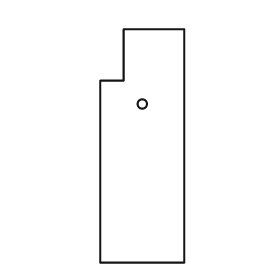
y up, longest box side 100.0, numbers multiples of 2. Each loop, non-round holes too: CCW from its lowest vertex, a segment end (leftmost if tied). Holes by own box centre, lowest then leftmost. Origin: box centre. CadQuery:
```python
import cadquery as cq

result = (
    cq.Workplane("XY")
    .moveTo(-18.0, -50.0)
    .lineTo(18.0, -50.0)
    .lineTo(18.0, 50.0)
    .lineTo(-8.0, 50.0)
    .lineTo(-8.0, 28.0)
    .lineTo(-18.0, 28.0)
    .close()
    .moveTo(0.0, 18.0)
    .circle(2.0)
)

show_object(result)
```